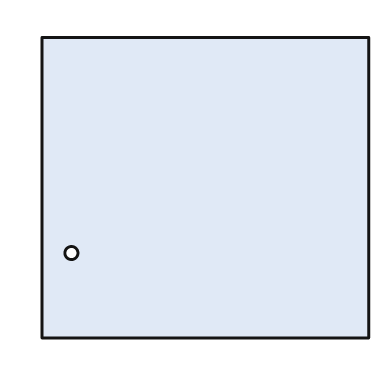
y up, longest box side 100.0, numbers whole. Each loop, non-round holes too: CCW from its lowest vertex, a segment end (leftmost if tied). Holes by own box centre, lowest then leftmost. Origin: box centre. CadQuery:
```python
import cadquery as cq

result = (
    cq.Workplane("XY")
    .moveTo(-50.0, -46.0)
    .lineTo(50.0, -46.0)
    .lineTo(50.0, 46.0)
    .lineTo(-50.0, 46.0)
    .close()
    .moveTo(-41.0, -20.0)
    .circle(2.0)
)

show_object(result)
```